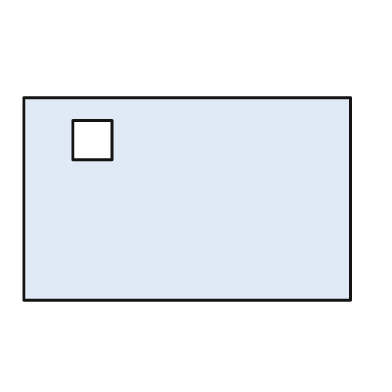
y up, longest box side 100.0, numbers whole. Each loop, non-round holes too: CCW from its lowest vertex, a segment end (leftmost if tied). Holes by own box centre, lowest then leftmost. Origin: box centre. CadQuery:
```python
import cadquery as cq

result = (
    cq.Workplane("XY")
    .moveTo(-50.0, -31.0)
    .lineTo(50.0, -31.0)
    .lineTo(50.0, 31.0)
    .lineTo(-50.0, 31.0)
    .close()
    .moveTo(-35.0, 12.0)
    .lineTo(-23.0, 12.0)
    .lineTo(-23.0, 24.0)
    .lineTo(-35.0, 24.0)
    .close()
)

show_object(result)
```